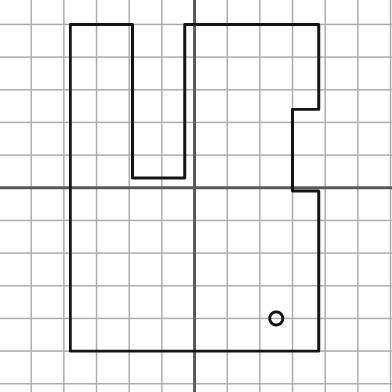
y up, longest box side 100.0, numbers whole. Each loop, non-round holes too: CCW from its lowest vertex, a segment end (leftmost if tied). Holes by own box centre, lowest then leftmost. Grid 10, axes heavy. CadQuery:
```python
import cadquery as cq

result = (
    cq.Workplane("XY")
    .moveTo(-38.0, -50.0)
    .lineTo(38.0, -50.0)
    .lineTo(38.0, -1.0)
    .lineTo(30.0, -1.0)
    .lineTo(30.0, 24.0)
    .lineTo(38.0, 24.0)
    .lineTo(38.0, 50.0)
    .lineTo(-3.0, 50.0)
    .lineTo(-3.0, 3.0)
    .lineTo(-19.0, 3.0)
    .lineTo(-19.0, 50.0)
    .lineTo(-38.0, 50.0)
    .close()
    .moveTo(25.0, -40.0)
    .circle(2.0)
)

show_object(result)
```